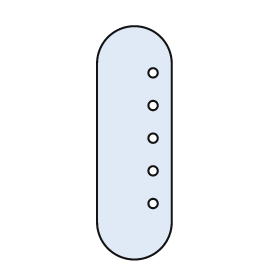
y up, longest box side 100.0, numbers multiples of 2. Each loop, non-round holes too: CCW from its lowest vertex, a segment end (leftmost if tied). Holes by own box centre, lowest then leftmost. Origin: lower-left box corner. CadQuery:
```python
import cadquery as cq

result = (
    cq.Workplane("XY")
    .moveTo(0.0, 16.0)
    .threePointArc((16.0, 0.0), (32.0, 16.0))
    .lineTo(32.0, 84.0)
    .threePointArc((16.0, 100.0), (0.0, 84.0))
    .close()
    .moveTo(24.0, 24.0)
    .circle(2.0)
    .moveTo(24.0, 38.0)
    .circle(2.0)
    .moveTo(24.0, 52.0)
    .circle(2.0)
    .moveTo(24.0, 66.0)
    .circle(2.0)
    .moveTo(24.0, 80.0)
    .circle(2.0)
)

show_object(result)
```